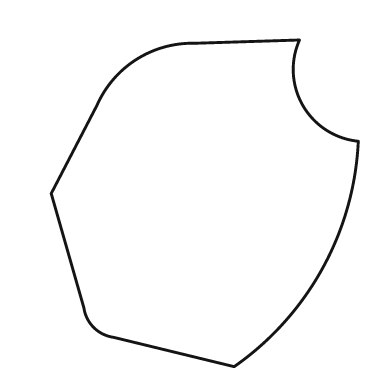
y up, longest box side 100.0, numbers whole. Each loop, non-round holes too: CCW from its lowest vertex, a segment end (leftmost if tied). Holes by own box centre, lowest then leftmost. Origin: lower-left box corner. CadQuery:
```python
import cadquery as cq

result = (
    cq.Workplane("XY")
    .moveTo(56.0, 0.0)
    .threePointArc((83.0, 30.0), (94.0, 69.0))
    .threePointArc((77.0, 80.0), (76.0, 100.0))
    .lineTo(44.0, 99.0)
    .threePointArc((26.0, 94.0), (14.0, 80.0))
    .lineTo(0.0, 53.0)
    .lineTo(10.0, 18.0)
    .threePointArc((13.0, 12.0), (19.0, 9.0))
    .close()
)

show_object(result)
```